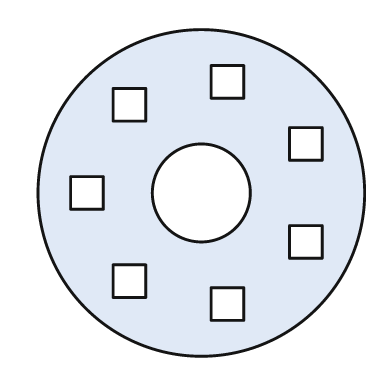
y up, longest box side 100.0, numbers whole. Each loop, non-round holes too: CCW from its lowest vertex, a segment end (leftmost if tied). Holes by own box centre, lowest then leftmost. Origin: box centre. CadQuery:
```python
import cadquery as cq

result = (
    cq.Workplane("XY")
    .moveTo(0.0, 0.0)
    .circle(50.0)
    .moveTo(3.0, -39.0)
    .lineTo(13.0, -39.0)
    .lineTo(13.0, -29.0)
    .lineTo(3.0, -29.0)
    .close()
    .moveTo(-27.0, -32.0)
    .lineTo(-17.0, -32.0)
    .lineTo(-17.0, -22.0)
    .lineTo(-27.0, -22.0)
    .close()
    .moveTo(27.0, -20.0)
    .lineTo(37.0, -20.0)
    .lineTo(37.0, -10.0)
    .lineTo(27.0, -10.0)
    .close()
    .moveTo(-40.0, -5.0)
    .lineTo(-30.0, -5.0)
    .lineTo(-30.0, 5.0)
    .lineTo(-40.0, 5.0)
    .close()
    .moveTo(0.0, 0.0)
    .circle(15.0)
    .moveTo(27.0, 10.0)
    .lineTo(37.0, 10.0)
    .lineTo(37.0, 20.0)
    .lineTo(27.0, 20.0)
    .close()
    .moveTo(-27.0, 22.0)
    .lineTo(-17.0, 22.0)
    .lineTo(-17.0, 32.0)
    .lineTo(-27.0, 32.0)
    .close()
    .moveTo(3.0, 29.0)
    .lineTo(13.0, 29.0)
    .lineTo(13.0, 39.0)
    .lineTo(3.0, 39.0)
    .close()
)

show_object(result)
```